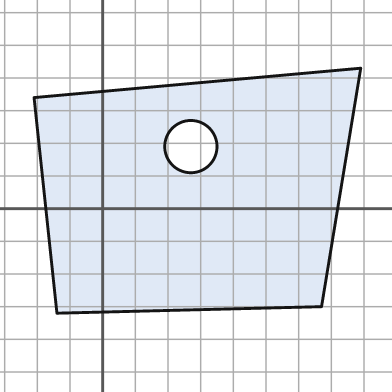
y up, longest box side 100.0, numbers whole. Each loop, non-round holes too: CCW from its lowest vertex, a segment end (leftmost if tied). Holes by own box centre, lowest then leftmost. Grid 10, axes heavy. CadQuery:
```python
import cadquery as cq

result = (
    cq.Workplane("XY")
    .moveTo(-14.0, -32.0)
    .lineTo(67.0, -30.0)
    .lineTo(79.0, 43.0)
    .lineTo(-21.0, 34.0)
    .close()
    .moveTo(27.0, 19.0)
    .circle(8.0)
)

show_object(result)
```